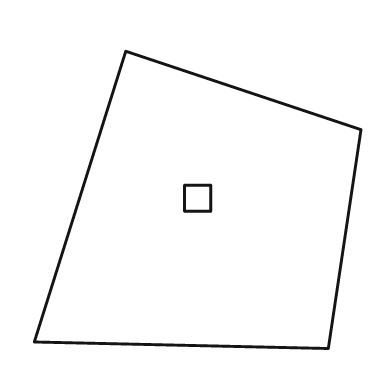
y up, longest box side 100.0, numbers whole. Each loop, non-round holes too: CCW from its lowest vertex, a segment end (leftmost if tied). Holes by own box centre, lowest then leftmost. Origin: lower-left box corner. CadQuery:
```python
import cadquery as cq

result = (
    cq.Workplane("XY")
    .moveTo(90.0, 0.0)
    .lineTo(100.0, 67.0)
    .lineTo(28.0, 91.0)
    .lineTo(0.0, 2.0)
    .close()
    .moveTo(46.0, 42.0)
    .lineTo(54.0, 42.0)
    .lineTo(54.0, 50.0)
    .lineTo(46.0, 50.0)
    .close()
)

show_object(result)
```